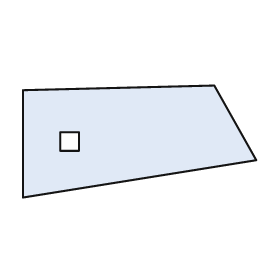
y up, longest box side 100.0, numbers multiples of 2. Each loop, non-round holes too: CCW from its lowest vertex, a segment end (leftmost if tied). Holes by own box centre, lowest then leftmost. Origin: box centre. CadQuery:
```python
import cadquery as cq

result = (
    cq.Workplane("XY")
    .moveTo(-50.0, -24.0)
    .lineTo(50.0, -8.0)
    .lineTo(32.0, 24.0)
    .lineTo(-50.0, 22.0)
    .close()
    .moveTo(-34.0, -4.0)
    .lineTo(-26.0, -4.0)
    .lineTo(-26.0, 4.0)
    .lineTo(-34.0, 4.0)
    .close()
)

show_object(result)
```